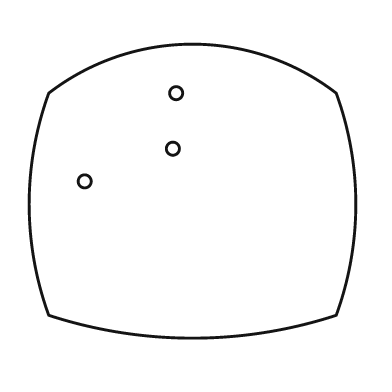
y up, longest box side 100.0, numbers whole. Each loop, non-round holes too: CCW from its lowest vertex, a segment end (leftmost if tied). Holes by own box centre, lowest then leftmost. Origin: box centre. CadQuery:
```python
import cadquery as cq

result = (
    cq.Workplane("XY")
    .moveTo(-44.0, -38.0)
    .threePointArc((0.0, -45.0), (44.0, -38.0))
    .threePointArc((50.0, -4.0), (44.0, 30.0))
    .threePointArc((0.0, 45.0), (-44.0, 30.0))
    .threePointArc((-50.0, -4.0), (-44.0, -38.0))
    .close()
    .moveTo(-33.0, 3.0)
    .circle(2.0)
    .moveTo(-6.0, 13.0)
    .circle(2.0)
    .moveTo(-5.0, 30.0)
    .circle(2.0)
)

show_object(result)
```